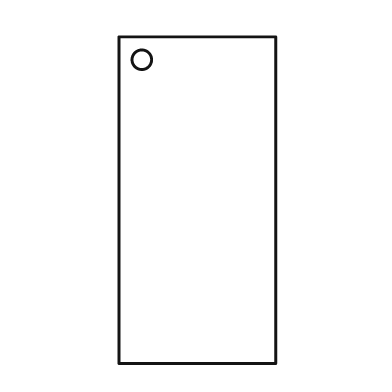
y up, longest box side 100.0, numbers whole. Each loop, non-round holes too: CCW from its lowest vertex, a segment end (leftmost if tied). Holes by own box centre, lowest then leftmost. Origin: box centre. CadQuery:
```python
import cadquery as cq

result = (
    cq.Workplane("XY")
    .moveTo(-24.0, -50.0)
    .lineTo(24.0, -50.0)
    .lineTo(24.0, 50.0)
    .lineTo(-24.0, 50.0)
    .close()
    .moveTo(-17.0, 43.0)
    .circle(3.0)
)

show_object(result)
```